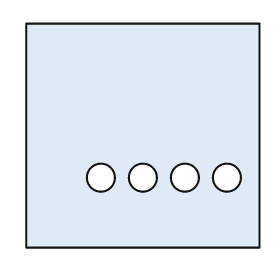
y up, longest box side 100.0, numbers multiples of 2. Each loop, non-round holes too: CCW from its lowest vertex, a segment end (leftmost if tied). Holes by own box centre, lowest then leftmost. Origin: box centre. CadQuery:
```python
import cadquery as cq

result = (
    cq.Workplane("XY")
    .moveTo(-50.0, -48.0)
    .lineTo(50.0, -48.0)
    .lineTo(50.0, 48.0)
    .lineTo(-50.0, 48.0)
    .close()
    .moveTo(-18.0, -18.0)
    .circle(6.0)
    .moveTo(0.0, -18.0)
    .circle(6.0)
    .moveTo(18.0, -18.0)
    .circle(6.0)
    .moveTo(36.0, -18.0)
    .circle(6.0)
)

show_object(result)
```